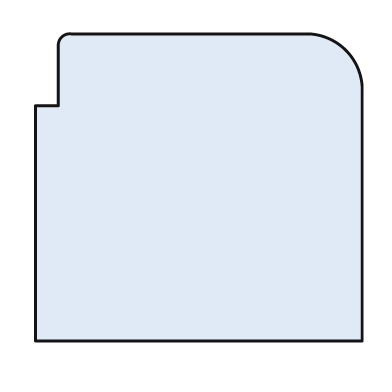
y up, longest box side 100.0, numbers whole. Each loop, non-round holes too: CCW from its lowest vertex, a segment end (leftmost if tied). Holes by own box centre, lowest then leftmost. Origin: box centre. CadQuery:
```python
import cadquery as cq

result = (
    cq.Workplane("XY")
    .moveTo(-50.0, -47.0)
    .lineTo(50.0, -47.0)
    .lineTo(50.0, 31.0)
    .threePointArc((45.0, 42.0), (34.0, 47.0))
    .lineTo(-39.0, 47.0)
    .threePointArc((-42.0, 46.0), (-43.0, 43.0))
    .lineTo(-43.0, 25.0)
    .lineTo(-50.0, 25.0)
    .close()
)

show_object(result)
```